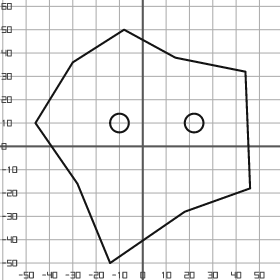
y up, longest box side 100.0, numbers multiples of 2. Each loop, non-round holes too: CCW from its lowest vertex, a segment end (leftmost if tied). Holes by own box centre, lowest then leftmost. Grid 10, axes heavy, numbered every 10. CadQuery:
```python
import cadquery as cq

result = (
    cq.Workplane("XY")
    .moveTo(-14.0, -50.0)
    .lineTo(18.0, -28.0)
    .lineTo(46.0, -18.0)
    .lineTo(44.0, 32.0)
    .lineTo(14.0, 38.0)
    .lineTo(-8.0, 50.0)
    .lineTo(-30.0, 36.0)
    .lineTo(-46.0, 10.0)
    .lineTo(-28.0, -16.0)
    .close()
    .moveTo(-10.0, 10.0)
    .circle(4.0)
    .moveTo(22.0, 10.0)
    .circle(4.0)
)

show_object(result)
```